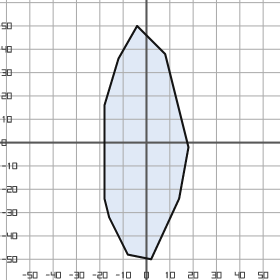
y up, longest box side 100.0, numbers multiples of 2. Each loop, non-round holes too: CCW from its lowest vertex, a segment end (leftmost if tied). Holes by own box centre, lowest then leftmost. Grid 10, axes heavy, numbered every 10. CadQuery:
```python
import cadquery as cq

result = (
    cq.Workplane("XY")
    .moveTo(2.0, -50.0)
    .lineTo(14.0, -24.0)
    .lineTo(18.0, -2.0)
    .lineTo(8.0, 38.0)
    .lineTo(-4.0, 50.0)
    .lineTo(-12.0, 36.0)
    .lineTo(-18.0, 16.0)
    .lineTo(-18.0, -24.0)
    .lineTo(-16.0, -32.0)
    .lineTo(-8.0, -48.0)
    .close()
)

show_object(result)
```